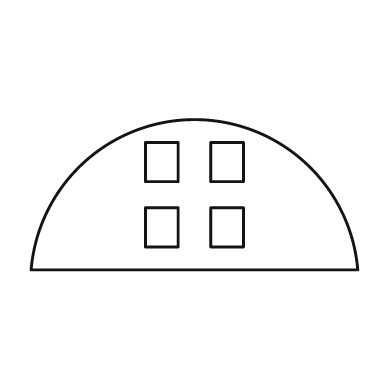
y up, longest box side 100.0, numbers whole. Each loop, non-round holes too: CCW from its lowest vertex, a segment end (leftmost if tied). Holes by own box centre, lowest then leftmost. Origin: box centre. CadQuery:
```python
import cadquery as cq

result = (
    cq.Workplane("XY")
    .moveTo(-50.0, -23.0)
    .lineTo(50.0, -23.0)
    .threePointArc((0.0, 23.0), (-50.0, -23.0))
    .close()
    .moveTo(-15.0, -16.0)
    .lineTo(-5.0, -16.0)
    .lineTo(-5.0, -4.0)
    .lineTo(-15.0, -4.0)
    .close()
    .moveTo(5.0, -16.0)
    .lineTo(15.0, -16.0)
    .lineTo(15.0, -4.0)
    .lineTo(5.0, -4.0)
    .close()
    .moveTo(-15.0, 4.0)
    .lineTo(-5.0, 4.0)
    .lineTo(-5.0, 16.0)
    .lineTo(-15.0, 16.0)
    .close()
    .moveTo(5.0, 4.0)
    .lineTo(15.0, 4.0)
    .lineTo(15.0, 16.0)
    .lineTo(5.0, 16.0)
    .close()
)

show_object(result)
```